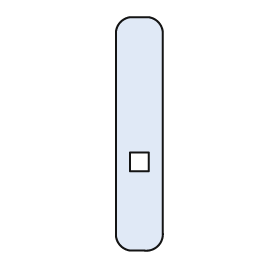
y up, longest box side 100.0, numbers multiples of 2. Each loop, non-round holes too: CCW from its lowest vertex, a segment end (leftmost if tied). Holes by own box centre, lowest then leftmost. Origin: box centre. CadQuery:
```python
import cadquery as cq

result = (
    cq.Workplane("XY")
    .moveTo(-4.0, -50.0)
    .lineTo(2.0, -50.0)
    .threePointArc((8.0, -48.0), (10.0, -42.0))
    .lineTo(10.0, 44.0)
    .threePointArc((8.0, 48.0), (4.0, 50.0))
    .lineTo(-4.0, 50.0)
    .threePointArc((-8.0, 48.0), (-10.0, 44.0))
    .lineTo(-10.0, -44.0)
    .threePointArc((-8.0, -48.0), (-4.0, -50.0))
    .close()
    .moveTo(-4.0, -16.0)
    .lineTo(4.0, -16.0)
    .lineTo(4.0, -8.0)
    .lineTo(-4.0, -8.0)
    .close()
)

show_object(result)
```